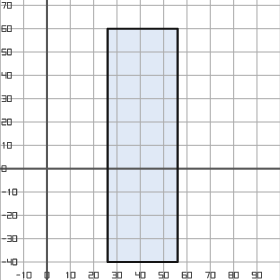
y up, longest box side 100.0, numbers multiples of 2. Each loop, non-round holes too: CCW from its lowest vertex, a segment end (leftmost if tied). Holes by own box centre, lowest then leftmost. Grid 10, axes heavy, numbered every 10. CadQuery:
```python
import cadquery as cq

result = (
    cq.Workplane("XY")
    .moveTo(26.0, -40.0)
    .lineTo(56.0, -40.0)
    .lineTo(56.0, 60.0)
    .lineTo(26.0, 60.0)
    .close()
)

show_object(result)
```